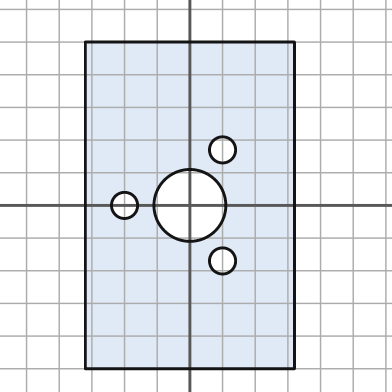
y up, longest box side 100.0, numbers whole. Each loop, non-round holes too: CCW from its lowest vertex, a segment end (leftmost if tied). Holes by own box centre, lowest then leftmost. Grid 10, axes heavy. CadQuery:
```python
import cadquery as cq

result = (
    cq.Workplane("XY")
    .moveTo(-32.0, -50.0)
    .lineTo(32.0, -50.0)
    .lineTo(32.0, 50.0)
    .lineTo(-32.0, 50.0)
    .close()
    .moveTo(10.0, -17.0)
    .circle(4.0)
    .moveTo(-20.0, 0.0)
    .circle(4.0)
    .moveTo(0.0, 0.0)
    .circle(11.0)
    .moveTo(10.0, 17.0)
    .circle(4.0)
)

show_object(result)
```